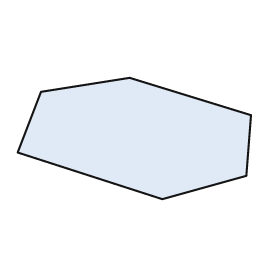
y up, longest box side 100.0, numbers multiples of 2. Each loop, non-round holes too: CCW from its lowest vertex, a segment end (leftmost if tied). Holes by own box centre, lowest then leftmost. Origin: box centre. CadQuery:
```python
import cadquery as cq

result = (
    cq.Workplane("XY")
    .moveTo(12.0, -26.0)
    .lineTo(48.0, -16.0)
    .lineTo(50.0, 10.0)
    .lineTo(-2.0, 26.0)
    .lineTo(-40.0, 20.0)
    .lineTo(-50.0, -6.0)
    .close()
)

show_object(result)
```